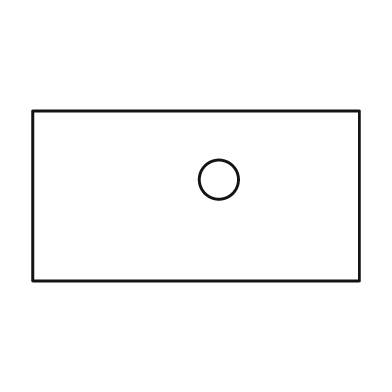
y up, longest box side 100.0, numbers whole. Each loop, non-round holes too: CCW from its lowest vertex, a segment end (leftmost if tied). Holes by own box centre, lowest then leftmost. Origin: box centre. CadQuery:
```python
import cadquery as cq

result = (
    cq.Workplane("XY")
    .moveTo(-50.0, -26.0)
    .lineTo(50.0, -26.0)
    .lineTo(50.0, 26.0)
    .lineTo(-50.0, 26.0)
    .close()
    .moveTo(7.0, 5.0)
    .circle(6.0)
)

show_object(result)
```